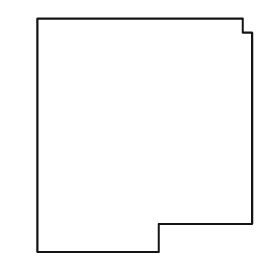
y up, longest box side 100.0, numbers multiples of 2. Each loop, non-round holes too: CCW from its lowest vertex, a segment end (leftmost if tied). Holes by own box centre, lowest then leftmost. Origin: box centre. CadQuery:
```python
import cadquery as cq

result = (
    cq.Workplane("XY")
    .moveTo(-46.0, -50.0)
    .lineTo(6.0, -50.0)
    .lineTo(6.0, -38.0)
    .lineTo(46.0, -38.0)
    .lineTo(46.0, 44.0)
    .lineTo(42.0, 44.0)
    .lineTo(42.0, 50.0)
    .lineTo(-46.0, 50.0)
    .close()
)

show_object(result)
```